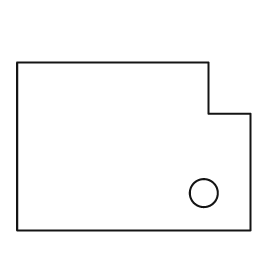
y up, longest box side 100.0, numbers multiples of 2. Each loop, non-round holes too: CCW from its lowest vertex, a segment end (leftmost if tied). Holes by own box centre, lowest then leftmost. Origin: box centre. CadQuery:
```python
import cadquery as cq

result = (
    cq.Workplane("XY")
    .moveTo(-50.0, -36.0)
    .lineTo(50.0, -36.0)
    .lineTo(50.0, 14.0)
    .lineTo(32.0, 14.0)
    .lineTo(32.0, 36.0)
    .lineTo(-50.0, 36.0)
    .close()
    .moveTo(30.0, -20.0)
    .circle(6.0)
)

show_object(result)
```